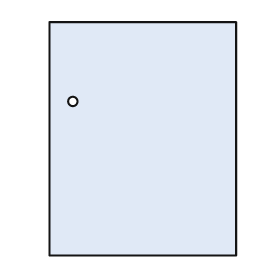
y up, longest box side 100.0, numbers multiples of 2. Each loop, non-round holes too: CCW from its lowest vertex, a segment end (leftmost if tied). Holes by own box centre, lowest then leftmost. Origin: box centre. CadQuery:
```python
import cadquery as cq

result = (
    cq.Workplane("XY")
    .moveTo(-40.0, -50.0)
    .lineTo(40.0, -50.0)
    .lineTo(40.0, 50.0)
    .lineTo(-40.0, 50.0)
    .close()
    .moveTo(-30.0, 16.0)
    .circle(2.0)
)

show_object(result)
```